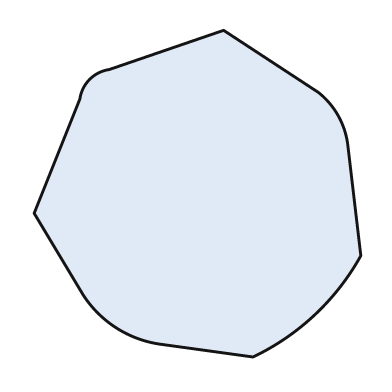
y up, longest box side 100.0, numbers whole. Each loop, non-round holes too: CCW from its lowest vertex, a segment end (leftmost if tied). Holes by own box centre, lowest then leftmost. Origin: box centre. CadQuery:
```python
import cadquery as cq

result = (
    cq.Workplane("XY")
    .moveTo(17.0, -50.0)
    .threePointArc((36.0, -37.0), (50.0, -19.0))
    .lineTo(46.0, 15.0)
    .threePointArc((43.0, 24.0), (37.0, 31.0))
    .lineTo(8.0, 50.0)
    .lineTo(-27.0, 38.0)
    .threePointArc((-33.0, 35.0), (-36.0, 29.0))
    .lineTo(-50.0, -6.0)
    .lineTo(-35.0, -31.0)
    .threePointArc((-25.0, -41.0), (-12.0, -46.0))
    .close()
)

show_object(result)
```